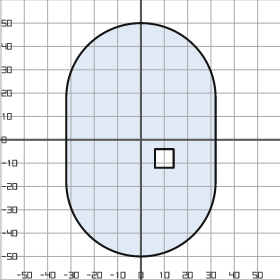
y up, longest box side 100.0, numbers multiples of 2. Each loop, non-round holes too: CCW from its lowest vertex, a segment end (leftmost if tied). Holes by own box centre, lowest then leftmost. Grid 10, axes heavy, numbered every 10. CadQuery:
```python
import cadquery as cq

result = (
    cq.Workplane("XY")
    .moveTo(-32.0, -18.0)
    .threePointArc((0.0, -50.0), (32.0, -18.0))
    .lineTo(32.0, 18.0)
    .threePointArc((0.0, 50.0), (-32.0, 18.0))
    .close()
    .moveTo(6.0, -12.0)
    .lineTo(14.0, -12.0)
    .lineTo(14.0, -4.0)
    .lineTo(6.0, -4.0)
    .close()
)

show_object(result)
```